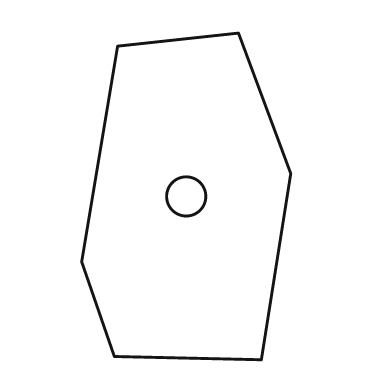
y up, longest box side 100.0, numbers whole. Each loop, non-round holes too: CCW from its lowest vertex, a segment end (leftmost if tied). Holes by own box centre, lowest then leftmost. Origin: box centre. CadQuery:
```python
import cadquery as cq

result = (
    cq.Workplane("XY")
    .moveTo(23.0, -50.0)
    .lineTo(32.0, 7.0)
    .lineTo(16.0, 50.0)
    .lineTo(-21.0, 46.0)
    .lineTo(-32.0, -20.0)
    .lineTo(-22.0, -49.0)
    .close()
    .moveTo(0.0, 0.0)
    .circle(6.0)
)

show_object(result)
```